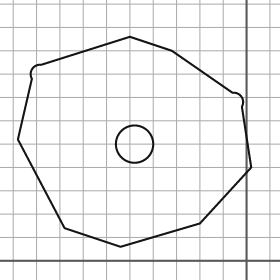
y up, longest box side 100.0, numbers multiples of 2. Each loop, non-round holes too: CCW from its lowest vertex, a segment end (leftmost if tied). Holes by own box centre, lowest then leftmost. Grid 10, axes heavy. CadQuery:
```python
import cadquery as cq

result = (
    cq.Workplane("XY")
    .moveTo(-54.0, 6.0)
    .lineTo(-20.0, 16.0)
    .lineTo(2.0, 40.0)
    .lineTo(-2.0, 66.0)
    .threePointArc((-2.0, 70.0), (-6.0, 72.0))
    .lineTo(-32.0, 90.0)
    .lineTo(-50.0, 96.0)
    .lineTo(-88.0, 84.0)
    .threePointArc((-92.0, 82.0), (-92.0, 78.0))
    .lineTo(-98.0, 52.0)
    .lineTo(-78.0, 14.0)
    .close()
    .moveTo(-48.0, 50.0)
    .circle(8.0)
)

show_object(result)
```